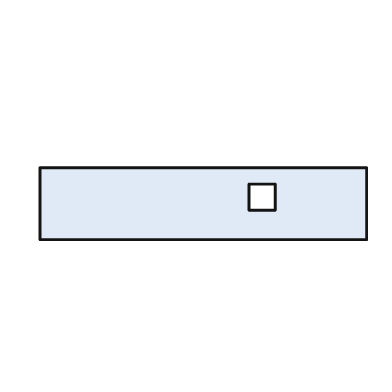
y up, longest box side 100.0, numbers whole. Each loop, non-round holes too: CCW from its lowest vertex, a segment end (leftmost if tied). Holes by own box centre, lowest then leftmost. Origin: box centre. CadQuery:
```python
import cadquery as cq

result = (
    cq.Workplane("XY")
    .moveTo(-50.0, -11.0)
    .lineTo(50.0, -11.0)
    .lineTo(50.0, 11.0)
    .lineTo(-50.0, 11.0)
    .close()
    .moveTo(14.0, -2.0)
    .lineTo(22.0, -2.0)
    .lineTo(22.0, 6.0)
    .lineTo(14.0, 6.0)
    .close()
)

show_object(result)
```